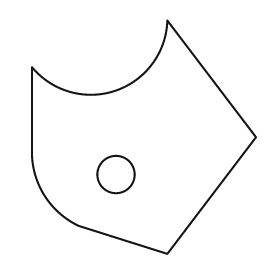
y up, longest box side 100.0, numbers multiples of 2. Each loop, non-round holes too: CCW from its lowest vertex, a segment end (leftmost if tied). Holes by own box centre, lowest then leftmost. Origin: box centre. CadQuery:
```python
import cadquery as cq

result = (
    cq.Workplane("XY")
    .moveTo(10.0, -50.0)
    .lineTo(48.0, 0.0)
    .lineTo(10.0, 50.0)
    .threePointArc((-12.0, 20.0), (-48.0, 30.0))
    .lineTo(-48.0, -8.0)
    .threePointArc((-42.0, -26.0), (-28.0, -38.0))
    .close()
    .moveTo(-12.0, -16.0)
    .circle(8.0)
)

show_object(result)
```